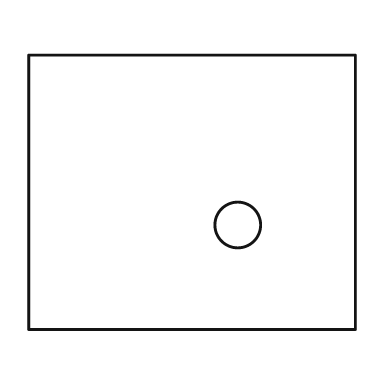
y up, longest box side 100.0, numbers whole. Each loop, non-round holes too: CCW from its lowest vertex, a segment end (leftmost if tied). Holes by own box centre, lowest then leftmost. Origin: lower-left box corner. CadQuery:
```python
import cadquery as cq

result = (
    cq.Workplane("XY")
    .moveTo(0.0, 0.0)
    .lineTo(100.0, 0.0)
    .lineTo(100.0, 84.0)
    .lineTo(0.0, 84.0)
    .close()
    .moveTo(64.0, 32.0)
    .circle(7.0)
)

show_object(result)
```